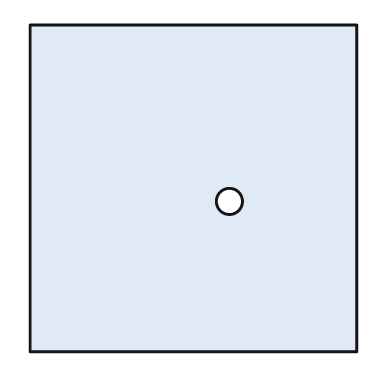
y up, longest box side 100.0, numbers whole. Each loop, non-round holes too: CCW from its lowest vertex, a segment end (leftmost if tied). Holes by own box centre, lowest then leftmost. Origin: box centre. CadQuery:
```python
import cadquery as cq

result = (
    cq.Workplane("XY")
    .moveTo(-50.0, -50.0)
    .lineTo(50.0, -50.0)
    .lineTo(50.0, 50.0)
    .lineTo(-50.0, 50.0)
    .close()
    .moveTo(11.0, -4.0)
    .circle(4.0)
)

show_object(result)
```